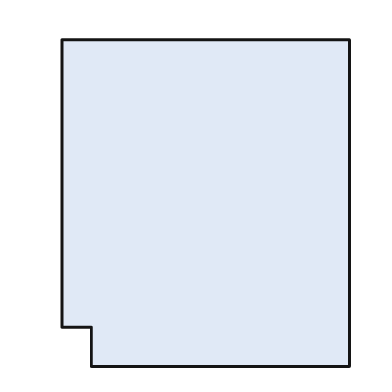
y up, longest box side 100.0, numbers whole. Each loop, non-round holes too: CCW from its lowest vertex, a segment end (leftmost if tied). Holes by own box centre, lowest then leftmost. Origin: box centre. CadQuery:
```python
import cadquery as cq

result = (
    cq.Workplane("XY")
    .moveTo(-35.0, -50.0)
    .lineTo(44.0, -50.0)
    .lineTo(44.0, 50.0)
    .lineTo(-44.0, 50.0)
    .lineTo(-44.0, -38.0)
    .lineTo(-35.0, -38.0)
    .close()
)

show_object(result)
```